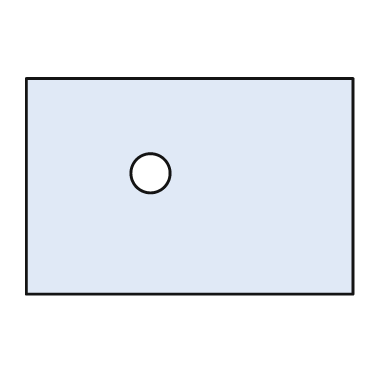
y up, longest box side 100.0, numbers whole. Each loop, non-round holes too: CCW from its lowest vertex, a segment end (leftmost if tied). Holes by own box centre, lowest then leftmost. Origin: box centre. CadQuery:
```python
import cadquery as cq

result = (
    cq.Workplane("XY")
    .moveTo(-50.0, -33.0)
    .lineTo(50.0, -33.0)
    .lineTo(50.0, 33.0)
    .lineTo(-50.0, 33.0)
    .close()
    .moveTo(-12.0, 4.0)
    .circle(6.0)
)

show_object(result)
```